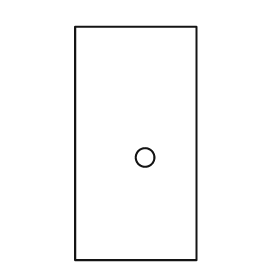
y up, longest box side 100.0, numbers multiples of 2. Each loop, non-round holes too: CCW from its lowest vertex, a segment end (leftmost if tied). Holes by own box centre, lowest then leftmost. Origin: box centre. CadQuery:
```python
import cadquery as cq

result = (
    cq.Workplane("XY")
    .moveTo(-26.0, -50.0)
    .lineTo(26.0, -50.0)
    .lineTo(26.0, 50.0)
    .lineTo(-26.0, 50.0)
    .close()
    .moveTo(4.0, -6.0)
    .circle(4.0)
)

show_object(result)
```